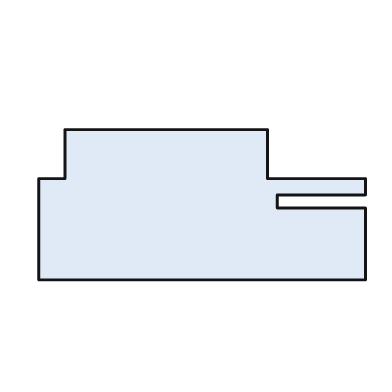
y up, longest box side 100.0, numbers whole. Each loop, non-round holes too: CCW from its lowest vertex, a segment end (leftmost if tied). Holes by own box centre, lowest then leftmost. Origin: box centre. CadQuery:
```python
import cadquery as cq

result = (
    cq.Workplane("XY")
    .moveTo(-50.0, -23.0)
    .lineTo(50.0, -23.0)
    .lineTo(50.0, -1.0)
    .lineTo(23.0, -1.0)
    .lineTo(23.0, 3.0)
    .lineTo(50.0, 3.0)
    .lineTo(50.0, 8.0)
    .lineTo(20.0, 8.0)
    .lineTo(20.0, 23.0)
    .lineTo(-42.0, 23.0)
    .lineTo(-42.0, 8.0)
    .lineTo(-50.0, 8.0)
    .close()
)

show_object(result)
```